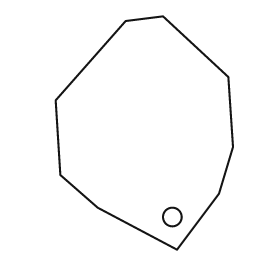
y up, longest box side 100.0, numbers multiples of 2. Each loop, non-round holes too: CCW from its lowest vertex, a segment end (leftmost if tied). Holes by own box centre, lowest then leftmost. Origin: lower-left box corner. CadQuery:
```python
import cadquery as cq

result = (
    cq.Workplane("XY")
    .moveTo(52.0, 0.0)
    .lineTo(70.0, 24.0)
    .lineTo(76.0, 44.0)
    .lineTo(74.0, 74.0)
    .lineTo(46.0, 100.0)
    .lineTo(30.0, 98.0)
    .lineTo(0.0, 64.0)
    .lineTo(2.0, 32.0)
    .lineTo(18.0, 18.0)
    .close()
    .moveTo(50.0, 14.0)
    .circle(4.0)
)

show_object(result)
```